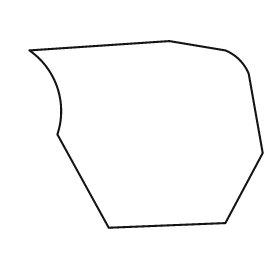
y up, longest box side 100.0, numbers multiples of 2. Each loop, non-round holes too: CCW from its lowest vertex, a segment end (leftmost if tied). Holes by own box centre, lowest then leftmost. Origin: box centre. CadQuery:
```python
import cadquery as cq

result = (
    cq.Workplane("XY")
    .moveTo(-16.0, -40.0)
    .lineTo(34.0, -38.0)
    .lineTo(50.0, -8.0)
    .lineTo(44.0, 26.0)
    .threePointArc((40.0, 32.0), (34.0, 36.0))
    .lineTo(10.0, 40.0)
    .lineTo(-50.0, 36.0)
    .threePointArc((-38.0, 20.0), (-38.0, 0.0))
    .close()
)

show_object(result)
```